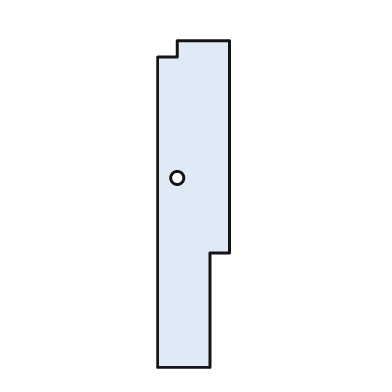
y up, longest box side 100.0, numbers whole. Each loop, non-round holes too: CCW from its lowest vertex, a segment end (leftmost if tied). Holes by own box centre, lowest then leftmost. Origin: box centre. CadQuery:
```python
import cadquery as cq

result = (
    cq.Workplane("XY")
    .moveTo(-11.0, -50.0)
    .lineTo(5.0, -50.0)
    .lineTo(5.0, -15.0)
    .lineTo(11.0, -15.0)
    .lineTo(11.0, 50.0)
    .lineTo(-5.0, 50.0)
    .lineTo(-5.0, 45.0)
    .lineTo(-11.0, 45.0)
    .close()
    .moveTo(-5.0, 8.0)
    .circle(2.0)
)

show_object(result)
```